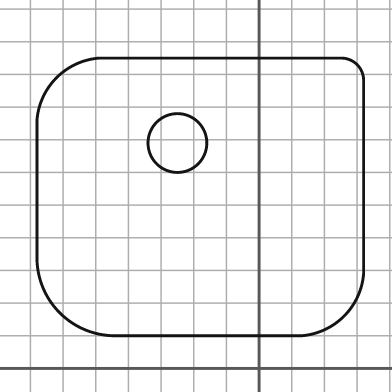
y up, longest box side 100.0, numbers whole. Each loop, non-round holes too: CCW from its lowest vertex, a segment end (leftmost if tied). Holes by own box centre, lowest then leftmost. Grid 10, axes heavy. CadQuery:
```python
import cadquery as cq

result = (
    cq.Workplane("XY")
    .moveTo(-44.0, 10.0)
    .lineTo(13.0, 10.0)
    .threePointArc((26.0, 16.0), (32.0, 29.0))
    .lineTo(32.0, 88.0)
    .threePointArc((30.0, 93.0), (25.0, 95.0))
    .lineTo(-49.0, 95.0)
    .threePointArc((-62.0, 89.0), (-68.0, 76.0))
    .lineTo(-68.0, 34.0)
    .threePointArc((-61.0, 17.0), (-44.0, 10.0))
    .close()
    .moveTo(-25.0, 69.0)
    .circle(9.0)
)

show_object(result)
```